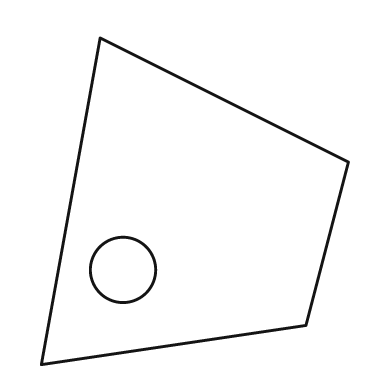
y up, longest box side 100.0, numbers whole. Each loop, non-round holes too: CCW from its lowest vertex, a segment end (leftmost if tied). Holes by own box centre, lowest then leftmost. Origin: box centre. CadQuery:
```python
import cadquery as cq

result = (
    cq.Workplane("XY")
    .moveTo(-47.0, -50.0)
    .lineTo(34.0, -38.0)
    .lineTo(47.0, 12.0)
    .lineTo(-29.0, 50.0)
    .close()
    .moveTo(-22.0, -21.0)
    .circle(10.0)
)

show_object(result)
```